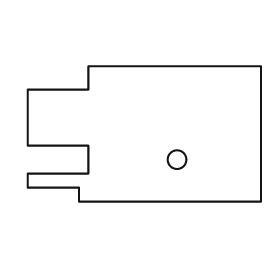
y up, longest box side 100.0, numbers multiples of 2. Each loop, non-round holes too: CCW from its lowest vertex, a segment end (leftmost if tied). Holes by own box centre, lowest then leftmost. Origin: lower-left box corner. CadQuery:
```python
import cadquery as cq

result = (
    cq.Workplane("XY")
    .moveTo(22.0, 0.0)
    .lineTo(100.0, 0.0)
    .lineTo(100.0, 58.0)
    .lineTo(26.0, 58.0)
    .lineTo(26.0, 48.0)
    .lineTo(0.0, 48.0)
    .lineTo(0.0, 24.0)
    .lineTo(26.0, 24.0)
    .lineTo(26.0, 12.0)
    .lineTo(0.0, 12.0)
    .lineTo(0.0, 6.0)
    .lineTo(22.0, 6.0)
    .close()
    .moveTo(64.0, 18.0)
    .circle(4.0)
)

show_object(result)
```